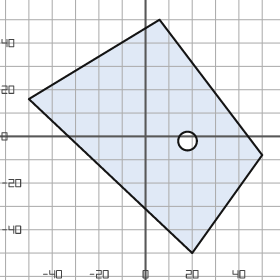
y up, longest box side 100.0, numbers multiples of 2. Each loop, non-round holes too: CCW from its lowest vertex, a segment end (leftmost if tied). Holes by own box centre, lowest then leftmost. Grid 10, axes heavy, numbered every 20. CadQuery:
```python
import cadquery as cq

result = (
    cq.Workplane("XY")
    .moveTo(20.0, -50.0)
    .lineTo(50.0, -8.0)
    .lineTo(6.0, 50.0)
    .lineTo(-50.0, 16.0)
    .close()
    .moveTo(18.0, -2.0)
    .circle(4.0)
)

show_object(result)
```